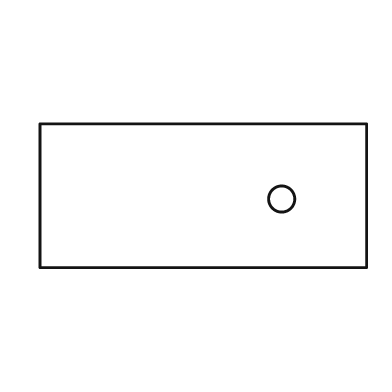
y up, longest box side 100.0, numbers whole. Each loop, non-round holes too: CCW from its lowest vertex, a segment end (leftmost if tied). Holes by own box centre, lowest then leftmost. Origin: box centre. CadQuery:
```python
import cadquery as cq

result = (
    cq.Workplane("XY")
    .moveTo(-50.0, -22.0)
    .lineTo(50.0, -22.0)
    .lineTo(50.0, 22.0)
    .lineTo(-50.0, 22.0)
    .close()
    .moveTo(24.0, -1.0)
    .circle(4.0)
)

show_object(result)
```